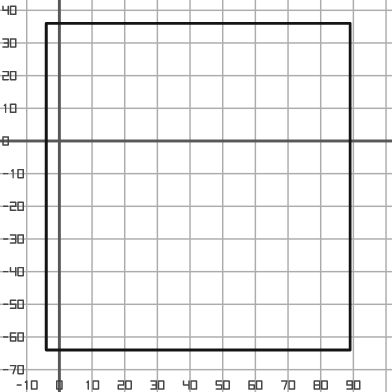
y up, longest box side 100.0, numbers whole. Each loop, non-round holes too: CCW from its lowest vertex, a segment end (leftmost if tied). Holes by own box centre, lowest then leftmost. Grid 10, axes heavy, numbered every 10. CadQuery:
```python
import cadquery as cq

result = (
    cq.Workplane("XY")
    .moveTo(-4.0, -64.0)
    .lineTo(89.0, -64.0)
    .lineTo(89.0, 36.0)
    .lineTo(-4.0, 36.0)
    .close()
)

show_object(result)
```